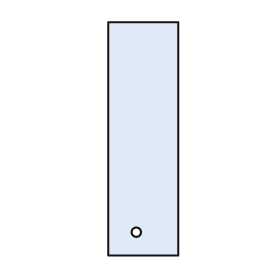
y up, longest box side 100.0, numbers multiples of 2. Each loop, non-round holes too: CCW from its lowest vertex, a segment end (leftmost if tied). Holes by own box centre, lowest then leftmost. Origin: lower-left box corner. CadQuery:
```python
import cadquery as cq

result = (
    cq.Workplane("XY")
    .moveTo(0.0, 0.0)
    .lineTo(30.0, 0.0)
    .lineTo(30.0, 100.0)
    .lineTo(0.0, 100.0)
    .close()
    .moveTo(12.0, 10.0)
    .circle(2.0)
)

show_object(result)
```